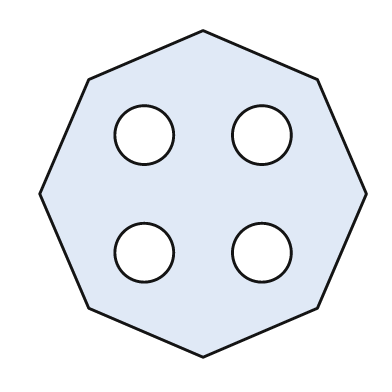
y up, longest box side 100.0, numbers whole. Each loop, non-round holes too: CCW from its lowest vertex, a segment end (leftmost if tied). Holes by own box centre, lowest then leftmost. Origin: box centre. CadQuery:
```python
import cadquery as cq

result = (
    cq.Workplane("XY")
    .moveTo(0.0, -50.0)
    .lineTo(35.0, -35.0)
    .lineTo(50.0, 0.0)
    .lineTo(35.0, 35.0)
    .lineTo(0.0, 50.0)
    .lineTo(-35.0, 35.0)
    .lineTo(-50.0, 0.0)
    .lineTo(-35.0, -35.0)
    .close()
    .moveTo(-18.0, -18.0)
    .circle(9.0)
    .moveTo(18.0, -18.0)
    .circle(9.0)
    .moveTo(-18.0, 18.0)
    .circle(9.0)
    .moveTo(18.0, 18.0)
    .circle(9.0)
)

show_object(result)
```